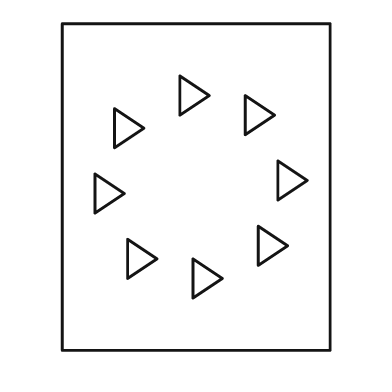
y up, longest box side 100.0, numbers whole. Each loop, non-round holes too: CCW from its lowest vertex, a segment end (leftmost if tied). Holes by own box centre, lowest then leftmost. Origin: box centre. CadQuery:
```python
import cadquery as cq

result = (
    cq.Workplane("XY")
    .moveTo(-41.0, -50.0)
    .lineTo(41.0, -50.0)
    .lineTo(41.0, 50.0)
    .lineTo(-41.0, 50.0)
    .close()
    .moveTo(-1.0, -34.0)
    .lineTo(8.0, -28.0)
    .lineTo(-1.0, -22.0)
    .close()
    .moveTo(-21.0, -28.0)
    .lineTo(-12.0, -22.0)
    .lineTo(-21.0, -16.0)
    .close()
    .moveTo(19.0, -24.0)
    .lineTo(28.0, -18.0)
    .lineTo(19.0, -12.0)
    .close()
    .moveTo(-31.0, -8.0)
    .lineTo(-22.0, -2.0)
    .lineTo(-31.0, 4.0)
    .close()
    .moveTo(25.0, -4.0)
    .lineTo(34.0, 2.0)
    .lineTo(25.0, 8.0)
    .close()
    .moveTo(-25.0, 12.0)
    .lineTo(-16.0, 18.0)
    .lineTo(-25.0, 24.0)
    .close()
    .moveTo(15.0, 16.0)
    .lineTo(24.0, 22.0)
    .lineTo(15.0, 28.0)
    .close()
    .moveTo(-5.0, 22.0)
    .lineTo(4.0, 28.0)
    .lineTo(-5.0, 34.0)
    .close()
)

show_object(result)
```